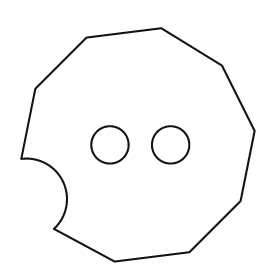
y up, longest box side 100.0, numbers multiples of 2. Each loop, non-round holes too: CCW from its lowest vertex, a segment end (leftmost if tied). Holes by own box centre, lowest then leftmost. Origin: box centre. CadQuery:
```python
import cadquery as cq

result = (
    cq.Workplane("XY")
    .moveTo(-10.0, -50.0)
    .lineTo(22.0, -46.0)
    .lineTo(44.0, -24.0)
    .lineTo(50.0, 6.0)
    .lineTo(36.0, 34.0)
    .lineTo(10.0, 50.0)
    .lineTo(-22.0, 46.0)
    .lineTo(-44.0, 24.0)
    .lineTo(-50.0, -6.0)
    .threePointArc((-32.0, -16.0), (-36.0, -36.0))
    .close()
    .moveTo(-12.0, 0.0)
    .circle(8.0)
    .moveTo(14.0, 0.0)
    .circle(8.0)
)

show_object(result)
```